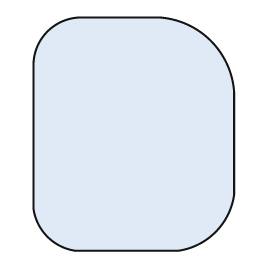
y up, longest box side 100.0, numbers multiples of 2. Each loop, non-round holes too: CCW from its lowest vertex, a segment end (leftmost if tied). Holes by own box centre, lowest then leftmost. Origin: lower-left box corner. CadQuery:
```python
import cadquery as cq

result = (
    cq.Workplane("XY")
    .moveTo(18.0, 0.0)
    .lineTo(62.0, 0.0)
    .threePointArc((78.0, 8.0), (86.0, 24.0))
    .lineTo(86.0, 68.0)
    .threePointArc((76.0, 90.0), (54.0, 100.0))
    .lineTo(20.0, 100.0)
    .threePointArc((6.0, 94.0), (0.0, 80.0))
    .lineTo(0.0, 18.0)
    .threePointArc((6.0, 6.0), (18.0, 0.0))
    .close()
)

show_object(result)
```